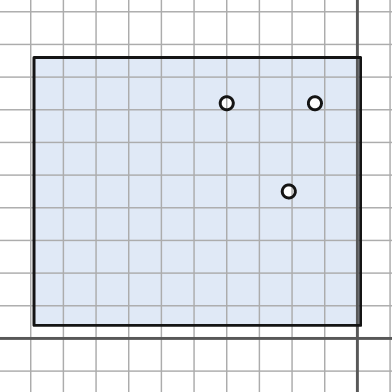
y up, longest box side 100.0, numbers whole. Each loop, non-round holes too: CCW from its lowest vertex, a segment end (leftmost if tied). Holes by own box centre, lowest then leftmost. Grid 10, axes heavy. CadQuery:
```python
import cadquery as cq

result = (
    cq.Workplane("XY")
    .moveTo(-99.0, 4.0)
    .lineTo(1.0, 4.0)
    .lineTo(1.0, 86.0)
    .lineTo(-99.0, 86.0)
    .close()
    .moveTo(-21.0, 45.0)
    .circle(2.0)
    .moveTo(-40.0, 72.0)
    .circle(2.0)
    .moveTo(-13.0, 72.0)
    .circle(2.0)
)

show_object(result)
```